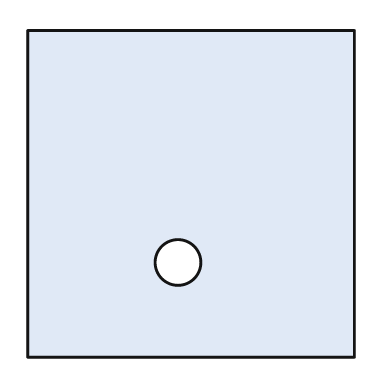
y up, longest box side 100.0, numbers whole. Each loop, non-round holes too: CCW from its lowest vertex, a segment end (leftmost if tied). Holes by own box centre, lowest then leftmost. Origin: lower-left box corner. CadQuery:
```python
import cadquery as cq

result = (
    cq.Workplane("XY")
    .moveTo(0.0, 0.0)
    .lineTo(100.0, 0.0)
    .lineTo(100.0, 100.0)
    .lineTo(0.0, 100.0)
    .close()
    .moveTo(46.0, 29.0)
    .circle(7.0)
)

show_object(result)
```